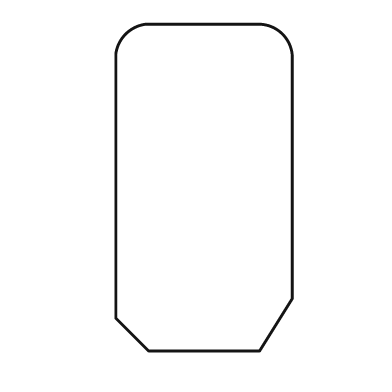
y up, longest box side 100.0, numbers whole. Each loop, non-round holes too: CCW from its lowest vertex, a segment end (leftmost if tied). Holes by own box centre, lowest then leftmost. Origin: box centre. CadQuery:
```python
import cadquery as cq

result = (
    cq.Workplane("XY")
    .moveTo(-17.0, -50.0)
    .lineTo(17.0, -50.0)
    .lineTo(27.0, -34.0)
    .lineTo(27.0, 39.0)
    .threePointArc((24.0, 47.0), (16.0, 50.0))
    .lineTo(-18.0, 50.0)
    .threePointArc((-24.0, 47.0), (-27.0, 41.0))
    .lineTo(-27.0, -40.0)
    .close()
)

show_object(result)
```